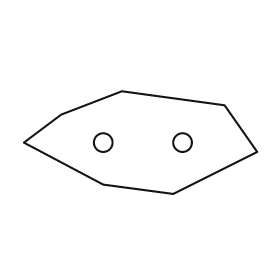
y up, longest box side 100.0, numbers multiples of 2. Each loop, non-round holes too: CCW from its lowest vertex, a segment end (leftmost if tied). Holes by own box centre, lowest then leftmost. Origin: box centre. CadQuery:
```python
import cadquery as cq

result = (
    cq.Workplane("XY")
    .moveTo(14.0, -22.0)
    .lineTo(50.0, -4.0)
    .lineTo(36.0, 16.0)
    .lineTo(-8.0, 22.0)
    .lineTo(-34.0, 12.0)
    .lineTo(-50.0, 0.0)
    .lineTo(-16.0, -18.0)
    .close()
    .moveTo(-16.0, 0.0)
    .circle(4.0)
    .moveTo(18.0, 0.0)
    .circle(4.0)
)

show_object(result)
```